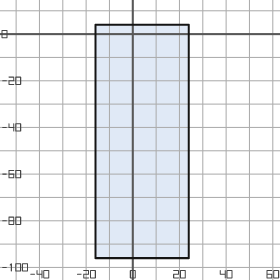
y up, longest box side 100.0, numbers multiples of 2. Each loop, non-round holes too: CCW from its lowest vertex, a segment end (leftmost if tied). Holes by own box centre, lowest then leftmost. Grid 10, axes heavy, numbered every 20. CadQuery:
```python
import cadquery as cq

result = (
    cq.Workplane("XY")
    .moveTo(-16.0, -96.0)
    .lineTo(24.0, -96.0)
    .lineTo(24.0, 4.0)
    .lineTo(-16.0, 4.0)
    .close()
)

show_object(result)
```